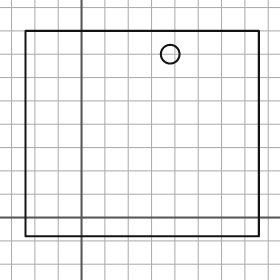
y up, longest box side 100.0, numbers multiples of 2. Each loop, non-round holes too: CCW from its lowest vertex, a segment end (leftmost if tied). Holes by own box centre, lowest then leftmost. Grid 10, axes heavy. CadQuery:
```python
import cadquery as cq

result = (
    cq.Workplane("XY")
    .moveTo(-24.0, -8.0)
    .lineTo(76.0, -8.0)
    .lineTo(76.0, 80.0)
    .lineTo(-24.0, 80.0)
    .close()
    .moveTo(38.0, 70.0)
    .circle(4.0)
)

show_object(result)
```